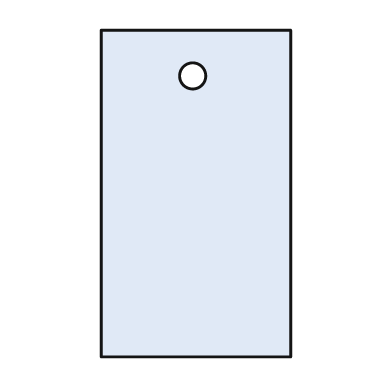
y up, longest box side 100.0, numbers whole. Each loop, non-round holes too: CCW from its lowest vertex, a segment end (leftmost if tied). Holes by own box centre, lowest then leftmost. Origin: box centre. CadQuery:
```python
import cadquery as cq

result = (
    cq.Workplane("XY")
    .moveTo(-29.0, -50.0)
    .lineTo(29.0, -50.0)
    .lineTo(29.0, 50.0)
    .lineTo(-29.0, 50.0)
    .close()
    .moveTo(-1.0, 36.0)
    .circle(4.0)
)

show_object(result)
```